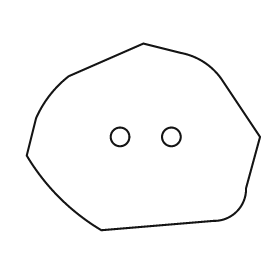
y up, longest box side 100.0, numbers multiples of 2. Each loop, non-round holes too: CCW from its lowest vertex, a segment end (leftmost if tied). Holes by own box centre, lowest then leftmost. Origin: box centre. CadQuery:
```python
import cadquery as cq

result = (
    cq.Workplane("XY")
    .moveTo(-18.0, -40.0)
    .lineTo(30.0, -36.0)
    .threePointArc((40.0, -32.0), (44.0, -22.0))
    .lineTo(50.0, 0.0)
    .lineTo(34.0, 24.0)
    .threePointArc((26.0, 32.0), (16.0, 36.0))
    .lineTo(0.0, 40.0)
    .lineTo(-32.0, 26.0)
    .threePointArc((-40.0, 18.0), (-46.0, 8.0))
    .lineTo(-50.0, -8.0)
    .threePointArc((-36.0, -26.0), (-18.0, -40.0))
    .close()
    .moveTo(-10.0, 0.0)
    .circle(4.0)
    .moveTo(12.0, 0.0)
    .circle(4.0)
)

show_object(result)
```